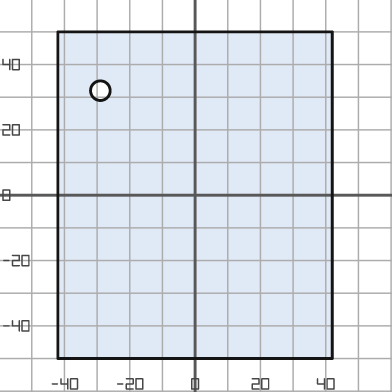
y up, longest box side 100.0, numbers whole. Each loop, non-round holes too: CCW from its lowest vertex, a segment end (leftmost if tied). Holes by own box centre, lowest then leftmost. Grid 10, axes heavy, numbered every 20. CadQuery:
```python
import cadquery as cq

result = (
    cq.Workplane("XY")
    .moveTo(-42.0, -50.0)
    .lineTo(42.0, -50.0)
    .lineTo(42.0, 50.0)
    .lineTo(-42.0, 50.0)
    .close()
    .moveTo(-29.0, 32.0)
    .circle(3.0)
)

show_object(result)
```